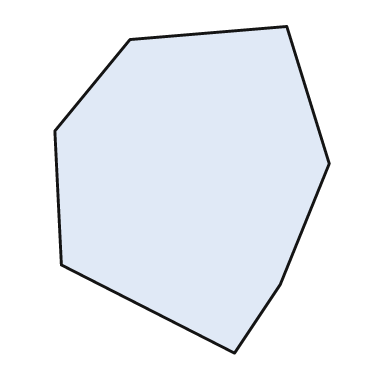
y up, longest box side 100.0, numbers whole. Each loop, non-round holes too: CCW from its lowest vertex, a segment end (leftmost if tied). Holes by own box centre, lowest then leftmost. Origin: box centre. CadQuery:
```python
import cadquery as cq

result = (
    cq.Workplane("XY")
    .moveTo(13.0, -50.0)
    .lineTo(27.0, -29.0)
    .lineTo(42.0, 8.0)
    .lineTo(29.0, 50.0)
    .lineTo(-19.0, 46.0)
    .lineTo(-42.0, 18.0)
    .lineTo(-40.0, -23.0)
    .close()
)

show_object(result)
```